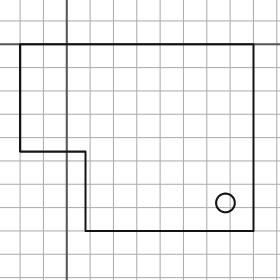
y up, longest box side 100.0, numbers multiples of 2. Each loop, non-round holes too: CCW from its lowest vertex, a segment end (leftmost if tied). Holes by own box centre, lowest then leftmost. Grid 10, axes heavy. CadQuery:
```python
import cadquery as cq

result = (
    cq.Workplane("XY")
    .moveTo(8.0, -80.0)
    .lineTo(80.0, -80.0)
    .lineTo(80.0, 0.0)
    .lineTo(-20.0, 0.0)
    .lineTo(-20.0, -46.0)
    .lineTo(8.0, -46.0)
    .close()
    .moveTo(68.0, -68.0)
    .circle(4.0)
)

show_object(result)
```